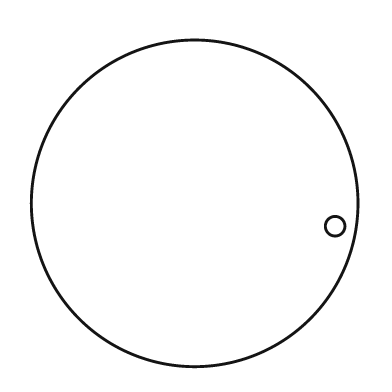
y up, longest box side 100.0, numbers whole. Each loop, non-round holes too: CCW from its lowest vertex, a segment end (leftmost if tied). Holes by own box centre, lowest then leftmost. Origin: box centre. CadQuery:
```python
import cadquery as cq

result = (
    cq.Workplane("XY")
    .moveTo(0.0, 0.0)
    .circle(50.0)
    .moveTo(43.0, -7.0)
    .circle(3.0)
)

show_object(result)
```